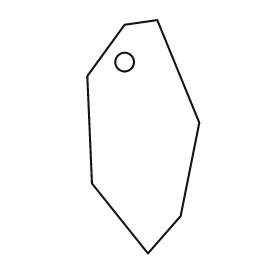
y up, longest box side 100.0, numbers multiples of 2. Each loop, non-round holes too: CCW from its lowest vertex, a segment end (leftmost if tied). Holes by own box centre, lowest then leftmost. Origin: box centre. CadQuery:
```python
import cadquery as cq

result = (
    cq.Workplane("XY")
    .moveTo(2.0, -50.0)
    .lineTo(16.0, -34.0)
    .lineTo(24.0, 6.0)
    .lineTo(6.0, 50.0)
    .lineTo(-8.0, 48.0)
    .lineTo(-24.0, 26.0)
    .lineTo(-22.0, -20.0)
    .close()
    .moveTo(-8.0, 32.0)
    .circle(4.0)
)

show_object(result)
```